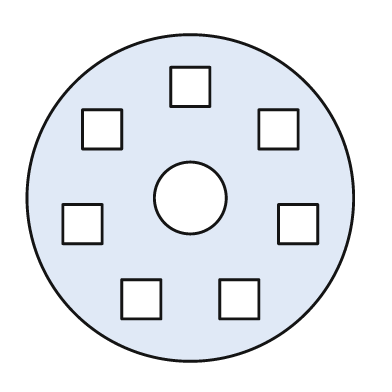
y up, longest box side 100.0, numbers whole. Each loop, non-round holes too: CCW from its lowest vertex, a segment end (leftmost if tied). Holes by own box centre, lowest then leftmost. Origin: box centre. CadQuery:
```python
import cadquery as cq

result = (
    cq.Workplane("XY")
    .moveTo(0.0, 0.0)
    .circle(50.0)
    .moveTo(-21.0, -37.0)
    .lineTo(-9.0, -37.0)
    .lineTo(-9.0, -25.0)
    .lineTo(-21.0, -25.0)
    .close()
    .moveTo(9.0, -37.0)
    .lineTo(21.0, -37.0)
    .lineTo(21.0, -25.0)
    .lineTo(9.0, -25.0)
    .close()
    .moveTo(-39.0, -14.0)
    .lineTo(-27.0, -14.0)
    .lineTo(-27.0, -2.0)
    .lineTo(-39.0, -2.0)
    .close()
    .moveTo(27.0, -14.0)
    .lineTo(39.0, -14.0)
    .lineTo(39.0, -2.0)
    .lineTo(27.0, -2.0)
    .close()
    .moveTo(0.0, 0.0)
    .circle(11.0)
    .moveTo(-33.0, 15.0)
    .lineTo(-21.0, 15.0)
    .lineTo(-21.0, 27.0)
    .lineTo(-33.0, 27.0)
    .close()
    .moveTo(21.0, 15.0)
    .lineTo(33.0, 15.0)
    .lineTo(33.0, 27.0)
    .lineTo(21.0, 27.0)
    .close()
    .moveTo(-6.0, 28.0)
    .lineTo(6.0, 28.0)
    .lineTo(6.0, 40.0)
    .lineTo(-6.0, 40.0)
    .close()
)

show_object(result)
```